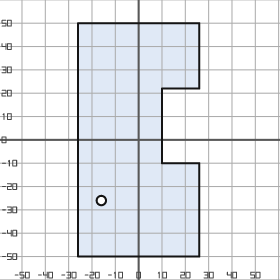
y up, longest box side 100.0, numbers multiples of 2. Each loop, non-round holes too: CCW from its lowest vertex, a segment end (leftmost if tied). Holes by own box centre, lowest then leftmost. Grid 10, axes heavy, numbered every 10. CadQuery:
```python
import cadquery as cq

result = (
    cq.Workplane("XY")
    .moveTo(-26.0, -50.0)
    .lineTo(26.0, -50.0)
    .lineTo(26.0, -10.0)
    .lineTo(10.0, -10.0)
    .lineTo(10.0, 22.0)
    .lineTo(26.0, 22.0)
    .lineTo(26.0, 50.0)
    .lineTo(-26.0, 50.0)
    .close()
    .moveTo(-16.0, -26.0)
    .circle(2.0)
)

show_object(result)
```